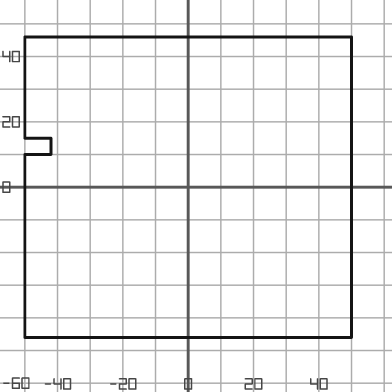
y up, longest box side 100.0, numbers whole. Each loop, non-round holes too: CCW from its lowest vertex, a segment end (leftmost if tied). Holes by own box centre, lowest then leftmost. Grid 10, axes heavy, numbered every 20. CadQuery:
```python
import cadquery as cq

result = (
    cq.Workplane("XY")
    .moveTo(-50.0, -46.0)
    .lineTo(50.0, -46.0)
    .lineTo(50.0, 46.0)
    .lineTo(-50.0, 46.0)
    .lineTo(-50.0, 15.0)
    .lineTo(-42.0, 15.0)
    .lineTo(-42.0, 10.0)
    .lineTo(-50.0, 10.0)
    .close()
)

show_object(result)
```